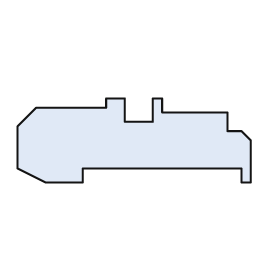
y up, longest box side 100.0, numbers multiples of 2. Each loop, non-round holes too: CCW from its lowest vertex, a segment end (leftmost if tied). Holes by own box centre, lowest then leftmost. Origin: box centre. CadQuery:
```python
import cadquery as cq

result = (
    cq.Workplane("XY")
    .moveTo(-38.0, -18.0)
    .lineTo(-22.0, -18.0)
    .lineTo(-22.0, -12.0)
    .lineTo(46.0, -12.0)
    .lineTo(46.0, -18.0)
    .lineTo(50.0, -18.0)
    .lineTo(50.0, 0.0)
    .lineTo(46.0, 4.0)
    .lineTo(40.0, 4.0)
    .lineTo(40.0, 12.0)
    .lineTo(12.0, 12.0)
    .lineTo(12.0, 18.0)
    .lineTo(8.0, 18.0)
    .lineTo(8.0, 8.0)
    .lineTo(-4.0, 8.0)
    .lineTo(-4.0, 18.0)
    .lineTo(-12.0, 18.0)
    .lineTo(-12.0, 14.0)
    .lineTo(-42.0, 14.0)
    .lineTo(-50.0, 6.0)
    .lineTo(-50.0, -12.0)
    .close()
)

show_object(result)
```